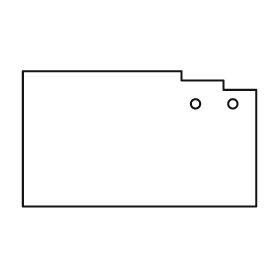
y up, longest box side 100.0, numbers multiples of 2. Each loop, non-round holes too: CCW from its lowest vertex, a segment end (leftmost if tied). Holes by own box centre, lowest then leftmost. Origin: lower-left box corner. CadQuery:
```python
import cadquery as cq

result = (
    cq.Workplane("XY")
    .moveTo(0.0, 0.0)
    .lineTo(100.0, 0.0)
    .lineTo(100.0, 50.0)
    .lineTo(86.0, 50.0)
    .lineTo(86.0, 54.0)
    .lineTo(68.0, 54.0)
    .lineTo(68.0, 58.0)
    .lineTo(0.0, 58.0)
    .close()
    .moveTo(74.0, 44.0)
    .circle(2.0)
    .moveTo(90.0, 44.0)
    .circle(2.0)
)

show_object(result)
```